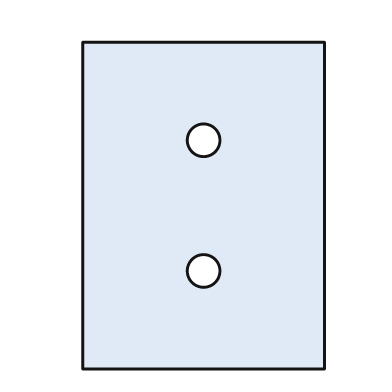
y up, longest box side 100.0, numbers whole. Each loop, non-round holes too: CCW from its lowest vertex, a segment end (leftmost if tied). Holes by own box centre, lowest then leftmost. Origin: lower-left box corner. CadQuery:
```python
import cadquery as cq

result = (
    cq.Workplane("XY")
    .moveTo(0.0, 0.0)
    .lineTo(74.0, 0.0)
    .lineTo(74.0, 100.0)
    .lineTo(0.0, 100.0)
    .close()
    .moveTo(37.0, 30.0)
    .circle(5.0)
    .moveTo(37.0, 70.0)
    .circle(5.0)
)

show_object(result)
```